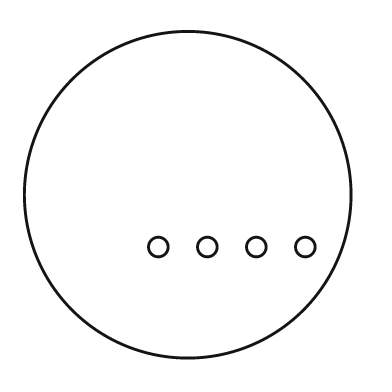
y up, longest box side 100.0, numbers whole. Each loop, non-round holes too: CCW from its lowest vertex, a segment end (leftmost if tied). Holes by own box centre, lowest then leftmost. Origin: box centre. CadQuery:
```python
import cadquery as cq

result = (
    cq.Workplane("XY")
    .moveTo(0.0, 0.0)
    .circle(50.0)
    .moveTo(-9.0, -16.0)
    .circle(3.0)
    .moveTo(6.0, -16.0)
    .circle(3.0)
    .moveTo(21.0, -16.0)
    .circle(3.0)
    .moveTo(36.0, -16.0)
    .circle(3.0)
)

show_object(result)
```